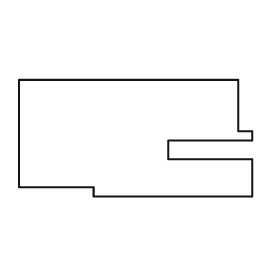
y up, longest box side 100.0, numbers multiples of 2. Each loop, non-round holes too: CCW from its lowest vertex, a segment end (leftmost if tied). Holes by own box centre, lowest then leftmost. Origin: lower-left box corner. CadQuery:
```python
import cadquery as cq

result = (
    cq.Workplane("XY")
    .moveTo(32.0, 0.0)
    .lineTo(100.0, 0.0)
    .lineTo(100.0, 16.0)
    .lineTo(64.0, 16.0)
    .lineTo(64.0, 24.0)
    .lineTo(100.0, 24.0)
    .lineTo(100.0, 28.0)
    .lineTo(94.0, 28.0)
    .lineTo(94.0, 50.0)
    .lineTo(0.0, 50.0)
    .lineTo(0.0, 4.0)
    .lineTo(32.0, 4.0)
    .close()
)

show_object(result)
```